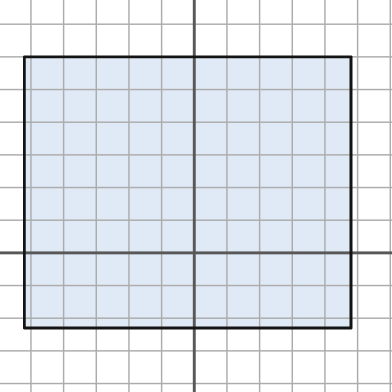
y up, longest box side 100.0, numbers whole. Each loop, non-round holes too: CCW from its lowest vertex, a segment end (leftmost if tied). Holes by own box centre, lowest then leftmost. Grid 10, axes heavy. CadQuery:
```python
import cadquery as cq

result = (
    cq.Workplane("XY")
    .moveTo(-52.0, -23.0)
    .lineTo(48.0, -23.0)
    .lineTo(48.0, 60.0)
    .lineTo(-52.0, 60.0)
    .close()
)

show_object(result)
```